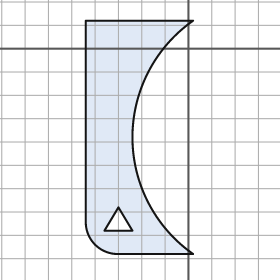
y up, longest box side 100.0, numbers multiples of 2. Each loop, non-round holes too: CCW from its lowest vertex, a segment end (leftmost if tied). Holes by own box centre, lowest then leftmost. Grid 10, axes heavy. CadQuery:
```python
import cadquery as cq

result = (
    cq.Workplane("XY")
    .moveTo(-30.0, -88.0)
    .lineTo(2.0, -88.0)
    .threePointArc((-24.0, -38.0), (2.0, 12.0))
    .lineTo(-44.0, 12.0)
    .lineTo(-44.0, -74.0)
    .threePointArc((-40.0, -84.0), (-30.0, -88.0))
    .close()
    .moveTo(-36.0, -78.0)
    .lineTo(-24.0, -78.0)
    .lineTo(-30.0, -68.0)
    .close()
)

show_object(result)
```